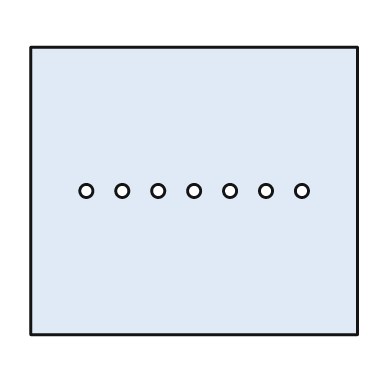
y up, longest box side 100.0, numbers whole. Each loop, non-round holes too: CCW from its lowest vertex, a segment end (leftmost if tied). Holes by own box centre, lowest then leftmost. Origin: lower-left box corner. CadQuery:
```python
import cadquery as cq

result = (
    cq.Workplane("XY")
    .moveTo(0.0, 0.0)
    .lineTo(100.0, 0.0)
    .lineTo(100.0, 88.0)
    .lineTo(0.0, 88.0)
    .close()
    .moveTo(17.0, 44.0)
    .circle(2.0)
    .moveTo(28.0, 44.0)
    .circle(2.0)
    .moveTo(39.0, 44.0)
    .circle(2.0)
    .moveTo(50.0, 44.0)
    .circle(2.0)
    .moveTo(61.0, 44.0)
    .circle(2.0)
    .moveTo(72.0, 44.0)
    .circle(2.0)
    .moveTo(83.0, 44.0)
    .circle(2.0)
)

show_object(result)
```